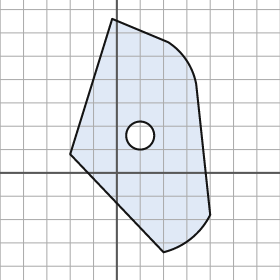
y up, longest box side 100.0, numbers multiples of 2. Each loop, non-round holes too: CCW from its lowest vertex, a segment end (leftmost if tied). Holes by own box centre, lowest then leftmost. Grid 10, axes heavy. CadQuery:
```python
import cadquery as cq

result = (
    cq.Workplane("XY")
    .moveTo(20.0, -34.0)
    .threePointArc((32.0, -28.0), (40.0, -18.0))
    .lineTo(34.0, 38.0)
    .threePointArc((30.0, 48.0), (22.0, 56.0))
    .lineTo(-2.0, 66.0)
    .lineTo(-20.0, 8.0)
    .close()
    .moveTo(10.0, 16.0)
    .circle(6.0)
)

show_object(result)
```